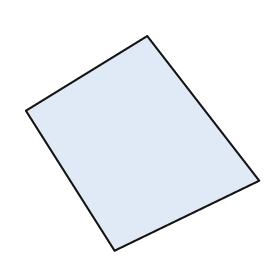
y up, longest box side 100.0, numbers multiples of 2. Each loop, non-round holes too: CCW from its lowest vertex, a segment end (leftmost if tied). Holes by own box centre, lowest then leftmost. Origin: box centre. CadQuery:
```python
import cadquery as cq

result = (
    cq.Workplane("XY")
    .moveTo(-12.0, -46.0)
    .lineTo(50.0, -16.0)
    .lineTo(2.0, 46.0)
    .lineTo(-50.0, 14.0)
    .close()
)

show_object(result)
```